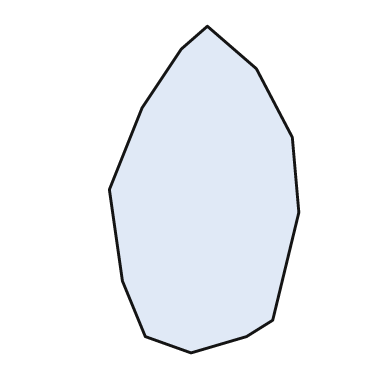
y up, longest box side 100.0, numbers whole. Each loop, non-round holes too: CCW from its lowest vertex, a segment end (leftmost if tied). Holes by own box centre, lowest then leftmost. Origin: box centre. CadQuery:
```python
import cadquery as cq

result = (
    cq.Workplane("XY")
    .moveTo(-4.0, -50.0)
    .lineTo(13.0, -45.0)
    .lineTo(21.0, -40.0)
    .lineTo(29.0, -7.0)
    .lineTo(27.0, 16.0)
    .lineTo(16.0, 37.0)
    .lineTo(1.0, 50.0)
    .lineTo(-7.0, 43.0)
    .lineTo(-19.0, 25.0)
    .lineTo(-29.0, 0.0)
    .lineTo(-25.0, -28.0)
    .lineTo(-18.0, -45.0)
    .close()
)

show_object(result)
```